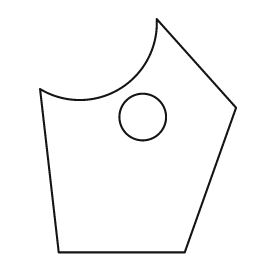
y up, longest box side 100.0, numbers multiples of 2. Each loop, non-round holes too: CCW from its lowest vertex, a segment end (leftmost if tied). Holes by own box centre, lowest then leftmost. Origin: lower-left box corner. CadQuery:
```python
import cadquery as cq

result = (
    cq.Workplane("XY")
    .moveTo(8.0, 0.0)
    .lineTo(62.0, 0.0)
    .lineTo(84.0, 62.0)
    .lineTo(50.0, 100.0)
    .threePointArc((34.0, 70.0), (0.0, 70.0))
    .close()
    .moveTo(44.0, 58.0)
    .circle(10.0)
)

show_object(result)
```